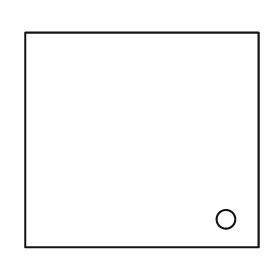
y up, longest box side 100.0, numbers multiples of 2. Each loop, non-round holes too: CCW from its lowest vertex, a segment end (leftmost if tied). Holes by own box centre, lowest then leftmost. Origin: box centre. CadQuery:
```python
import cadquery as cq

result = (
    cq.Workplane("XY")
    .moveTo(-50.0, -46.0)
    .lineTo(50.0, -46.0)
    .lineTo(50.0, 46.0)
    .lineTo(-50.0, 46.0)
    .close()
    .moveTo(36.0, -34.0)
    .circle(4.0)
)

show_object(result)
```